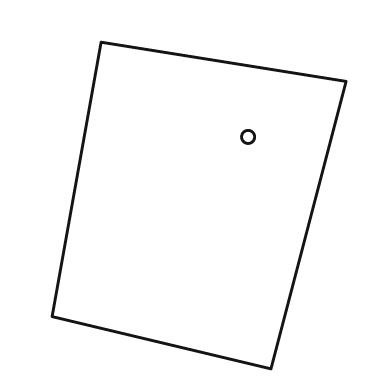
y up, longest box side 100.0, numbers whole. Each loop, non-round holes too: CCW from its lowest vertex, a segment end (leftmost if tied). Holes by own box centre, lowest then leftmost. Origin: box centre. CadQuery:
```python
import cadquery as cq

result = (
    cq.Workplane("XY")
    .moveTo(22.0, -50.0)
    .lineTo(45.0, 38.0)
    .lineTo(-30.0, 50.0)
    .lineTo(-45.0, -34.0)
    .close()
    .moveTo(15.0, 21.0)
    .circle(2.0)
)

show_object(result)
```